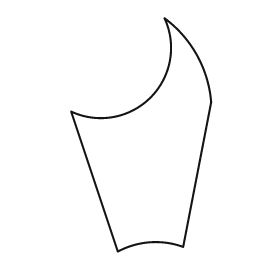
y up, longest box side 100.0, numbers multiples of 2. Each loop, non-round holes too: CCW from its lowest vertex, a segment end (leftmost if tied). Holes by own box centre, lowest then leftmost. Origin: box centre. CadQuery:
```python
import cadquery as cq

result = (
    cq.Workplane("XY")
    .moveTo(-10.0, -50.0)
    .threePointArc((4.0, -46.0), (18.0, -48.0))
    .lineTo(30.0, 14.0)
    .threePointArc((24.0, 34.0), (10.0, 50.0))
    .threePointArc((4.0, 16.0), (-30.0, 10.0))
    .close()
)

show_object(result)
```